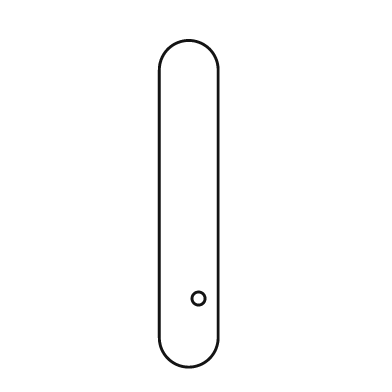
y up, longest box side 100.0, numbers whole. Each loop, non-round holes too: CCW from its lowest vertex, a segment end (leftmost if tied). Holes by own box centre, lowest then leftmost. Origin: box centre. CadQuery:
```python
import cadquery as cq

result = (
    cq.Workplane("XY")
    .moveTo(-9.0, -41.0)
    .threePointArc((0.0, -50.0), (9.0, -41.0))
    .lineTo(9.0, 41.0)
    .threePointArc((0.0, 50.0), (-9.0, 41.0))
    .close()
    .moveTo(3.0, -29.0)
    .circle(2.0)
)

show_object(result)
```